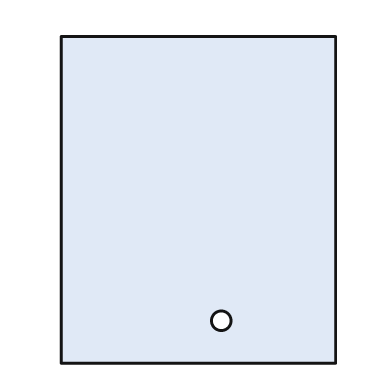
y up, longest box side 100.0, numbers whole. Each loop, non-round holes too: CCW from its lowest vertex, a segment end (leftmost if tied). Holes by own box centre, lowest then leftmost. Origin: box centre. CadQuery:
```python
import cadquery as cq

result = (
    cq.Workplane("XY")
    .moveTo(-42.0, -50.0)
    .lineTo(42.0, -50.0)
    .lineTo(42.0, 50.0)
    .lineTo(-42.0, 50.0)
    .close()
    .moveTo(7.0, -37.0)
    .circle(3.0)
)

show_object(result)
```